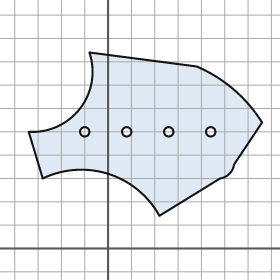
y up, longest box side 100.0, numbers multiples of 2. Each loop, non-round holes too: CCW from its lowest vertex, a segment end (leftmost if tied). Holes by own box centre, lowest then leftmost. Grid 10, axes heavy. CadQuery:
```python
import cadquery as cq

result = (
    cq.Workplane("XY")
    .moveTo(22.0, 14.0)
    .lineTo(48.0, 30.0)
    .threePointArc((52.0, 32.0), (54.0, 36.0))
    .lineTo(66.0, 54.0)
    .threePointArc((54.0, 68.0), (38.0, 78.0))
    .lineTo(-8.0, 84.0)
    .threePointArc((-12.0, 60.0), (-34.0, 50.0))
    .lineTo(-28.0, 30.0)
    .threePointArc((0.0, 32.0), (22.0, 14.0))
    .close()
    .moveTo(-10.0, 50.0)
    .circle(2.0)
    .moveTo(8.0, 50.0)
    .circle(2.0)
    .moveTo(26.0, 50.0)
    .circle(2.0)
    .moveTo(44.0, 50.0)
    .circle(2.0)
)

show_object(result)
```